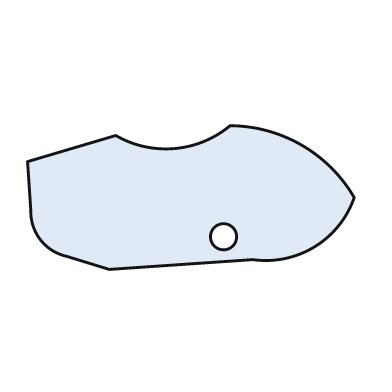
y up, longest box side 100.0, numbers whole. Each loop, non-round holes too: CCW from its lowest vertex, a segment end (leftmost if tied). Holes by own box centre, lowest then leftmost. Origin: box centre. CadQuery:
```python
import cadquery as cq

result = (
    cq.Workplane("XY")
    .moveTo(-25.0, -22.0)
    .lineTo(19.0, -19.0)
    .threePointArc((38.0, -15.0), (50.0, 0.0))
    .threePointArc((34.0, 16.0), (12.0, 22.0))
    .threePointArc((-5.0, 15.0), (-23.0, 19.0))
    .lineTo(-50.0, 11.0)
    .lineTo(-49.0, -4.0)
    .threePointArc((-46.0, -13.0), (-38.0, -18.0))
    .close()
    .moveTo(10.0, -12.0)
    .circle(4.0)
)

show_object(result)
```